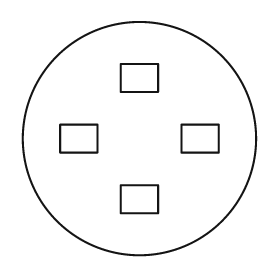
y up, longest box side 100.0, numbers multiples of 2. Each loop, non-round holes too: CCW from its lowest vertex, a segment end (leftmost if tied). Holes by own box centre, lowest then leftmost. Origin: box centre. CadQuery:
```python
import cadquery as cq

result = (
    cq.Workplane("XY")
    .moveTo(0.0, 0.0)
    .circle(50.0)
    .moveTo(-8.0, -32.0)
    .lineTo(8.0, -32.0)
    .lineTo(8.0, -20.0)
    .lineTo(-8.0, -20.0)
    .close()
    .moveTo(-34.0, -6.0)
    .lineTo(-18.0, -6.0)
    .lineTo(-18.0, 6.0)
    .lineTo(-34.0, 6.0)
    .close()
    .moveTo(18.0, -6.0)
    .lineTo(34.0, -6.0)
    .lineTo(34.0, 6.0)
    .lineTo(18.0, 6.0)
    .close()
    .moveTo(-8.0, 20.0)
    .lineTo(8.0, 20.0)
    .lineTo(8.0, 32.0)
    .lineTo(-8.0, 32.0)
    .close()
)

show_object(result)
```